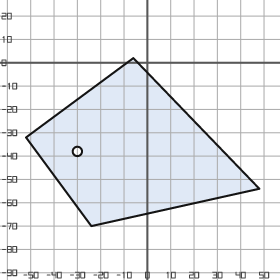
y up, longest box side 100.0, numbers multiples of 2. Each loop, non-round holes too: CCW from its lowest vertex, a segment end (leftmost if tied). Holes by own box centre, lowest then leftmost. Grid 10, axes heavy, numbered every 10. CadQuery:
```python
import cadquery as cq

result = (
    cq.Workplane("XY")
    .moveTo(-24.0, -70.0)
    .lineTo(48.0, -54.0)
    .lineTo(-6.0, 2.0)
    .lineTo(-52.0, -32.0)
    .close()
    .moveTo(-30.0, -38.0)
    .circle(2.0)
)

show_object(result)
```